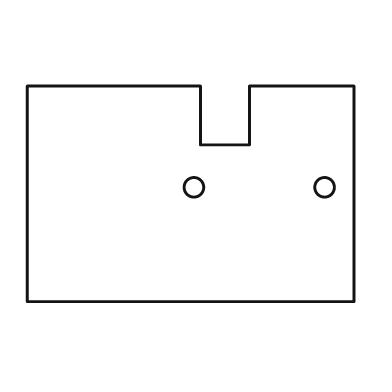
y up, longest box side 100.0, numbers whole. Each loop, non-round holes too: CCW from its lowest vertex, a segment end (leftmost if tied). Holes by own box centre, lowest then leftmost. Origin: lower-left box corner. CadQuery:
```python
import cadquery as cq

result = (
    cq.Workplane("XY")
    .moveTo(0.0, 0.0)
    .lineTo(100.0, 0.0)
    .lineTo(100.0, 66.0)
    .lineTo(68.0, 66.0)
    .lineTo(68.0, 48.0)
    .lineTo(53.0, 48.0)
    .lineTo(53.0, 66.0)
    .lineTo(0.0, 66.0)
    .close()
    .moveTo(51.0, 35.0)
    .circle(3.0)
    .moveTo(91.0, 35.0)
    .circle(3.0)
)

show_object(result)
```